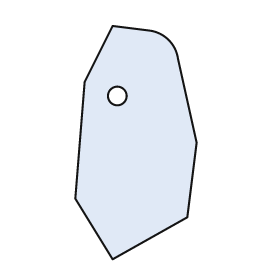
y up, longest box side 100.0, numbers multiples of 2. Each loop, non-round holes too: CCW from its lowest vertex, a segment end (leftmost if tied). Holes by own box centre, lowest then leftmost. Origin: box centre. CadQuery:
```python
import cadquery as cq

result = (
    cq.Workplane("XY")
    .moveTo(-10.0, -50.0)
    .lineTo(22.0, -32.0)
    .lineTo(26.0, 0.0)
    .lineTo(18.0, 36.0)
    .threePointArc((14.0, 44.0), (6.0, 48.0))
    .lineTo(-10.0, 50.0)
    .lineTo(-22.0, 26.0)
    .lineTo(-26.0, -24.0)
    .close()
    .moveTo(-8.0, 20.0)
    .circle(4.0)
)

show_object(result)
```